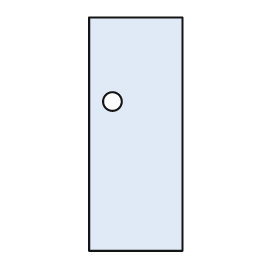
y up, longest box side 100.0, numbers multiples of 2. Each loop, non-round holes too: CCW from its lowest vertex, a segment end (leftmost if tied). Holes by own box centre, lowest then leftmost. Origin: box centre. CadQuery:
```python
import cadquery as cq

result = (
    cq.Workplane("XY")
    .moveTo(-20.0, -50.0)
    .lineTo(20.0, -50.0)
    .lineTo(20.0, 50.0)
    .lineTo(-20.0, 50.0)
    .close()
    .moveTo(-10.0, 14.0)
    .circle(4.0)
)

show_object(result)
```